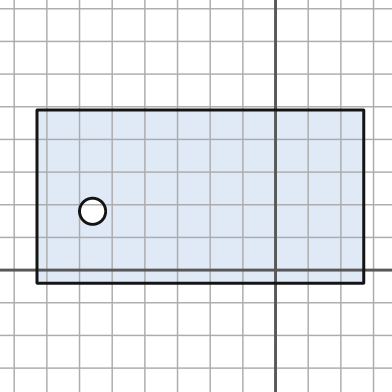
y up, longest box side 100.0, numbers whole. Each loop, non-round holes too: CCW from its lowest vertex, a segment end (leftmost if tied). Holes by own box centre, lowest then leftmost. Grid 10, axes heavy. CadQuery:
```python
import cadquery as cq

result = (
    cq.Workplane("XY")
    .moveTo(-73.0, -4.0)
    .lineTo(27.0, -4.0)
    .lineTo(27.0, 49.0)
    .lineTo(-73.0, 49.0)
    .close()
    .moveTo(-56.0, 18.0)
    .circle(4.0)
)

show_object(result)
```